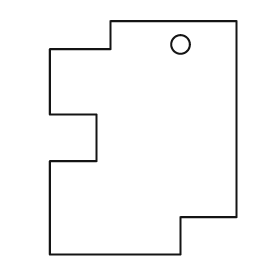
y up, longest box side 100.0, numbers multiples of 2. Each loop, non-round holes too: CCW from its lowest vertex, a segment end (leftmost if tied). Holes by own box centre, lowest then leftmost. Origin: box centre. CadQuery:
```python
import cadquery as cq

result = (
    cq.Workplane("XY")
    .moveTo(-40.0, -50.0)
    .lineTo(16.0, -50.0)
    .lineTo(16.0, -34.0)
    .lineTo(40.0, -34.0)
    .lineTo(40.0, 50.0)
    .lineTo(-14.0, 50.0)
    .lineTo(-14.0, 38.0)
    .lineTo(-40.0, 38.0)
    .lineTo(-40.0, 10.0)
    .lineTo(-20.0, 10.0)
    .lineTo(-20.0, -10.0)
    .lineTo(-40.0, -10.0)
    .close()
    .moveTo(16.0, 40.0)
    .circle(4.0)
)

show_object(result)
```